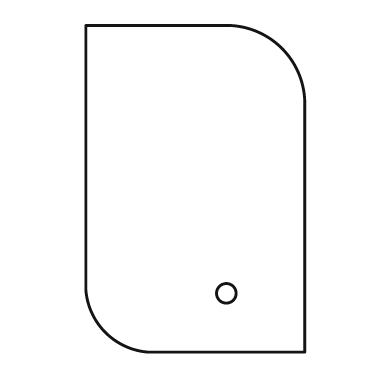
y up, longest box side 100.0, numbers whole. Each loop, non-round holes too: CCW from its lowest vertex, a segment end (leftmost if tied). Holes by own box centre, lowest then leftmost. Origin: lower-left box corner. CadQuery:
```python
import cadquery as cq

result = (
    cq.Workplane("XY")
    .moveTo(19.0, 0.0)
    .lineTo(67.0, 0.0)
    .lineTo(67.0, 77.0)
    .threePointArc((60.0, 93.0), (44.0, 100.0))
    .lineTo(0.0, 100.0)
    .lineTo(0.0, 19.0)
    .threePointArc((6.0, 6.0), (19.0, 0.0))
    .close()
    .moveTo(43.0, 18.0)
    .circle(3.0)
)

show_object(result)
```